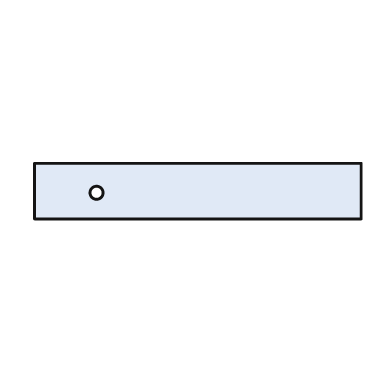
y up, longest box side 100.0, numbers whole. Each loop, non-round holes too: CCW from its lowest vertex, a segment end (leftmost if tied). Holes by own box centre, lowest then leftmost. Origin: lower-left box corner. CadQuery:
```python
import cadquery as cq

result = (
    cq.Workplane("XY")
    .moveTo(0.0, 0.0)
    .lineTo(100.0, 0.0)
    .lineTo(100.0, 17.0)
    .lineTo(0.0, 17.0)
    .close()
    .moveTo(19.0, 8.0)
    .circle(2.0)
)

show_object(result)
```